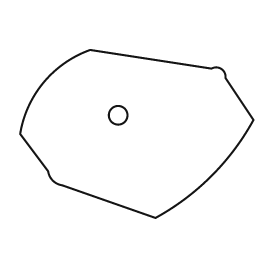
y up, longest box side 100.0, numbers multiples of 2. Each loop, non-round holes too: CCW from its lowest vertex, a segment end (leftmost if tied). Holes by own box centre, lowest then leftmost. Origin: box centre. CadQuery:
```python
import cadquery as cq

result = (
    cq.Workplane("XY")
    .moveTo(8.0, -36.0)
    .threePointArc((32.0, -18.0), (50.0, 6.0))
    .lineTo(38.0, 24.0)
    .threePointArc((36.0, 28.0), (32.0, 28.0))
    .lineTo(-20.0, 36.0)
    .threePointArc((-40.0, 22.0), (-50.0, 0.0))
    .lineTo(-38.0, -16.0)
    .threePointArc((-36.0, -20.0), (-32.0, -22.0))
    .close()
    .moveTo(-8.0, 8.0)
    .circle(4.0)
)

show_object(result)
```